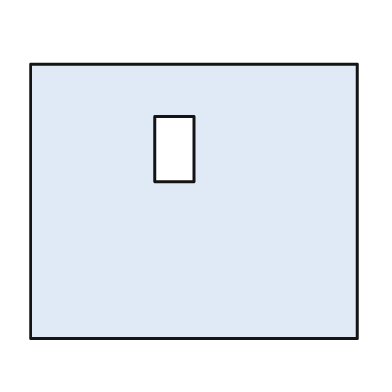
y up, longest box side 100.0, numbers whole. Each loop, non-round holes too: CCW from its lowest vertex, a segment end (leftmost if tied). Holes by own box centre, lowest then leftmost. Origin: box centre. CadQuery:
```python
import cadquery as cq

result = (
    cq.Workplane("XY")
    .moveTo(-50.0, -42.0)
    .lineTo(50.0, -42.0)
    .lineTo(50.0, 42.0)
    .lineTo(-50.0, 42.0)
    .close()
    .moveTo(-12.0, 6.0)
    .lineTo(0.0, 6.0)
    .lineTo(0.0, 26.0)
    .lineTo(-12.0, 26.0)
    .close()
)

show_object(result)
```